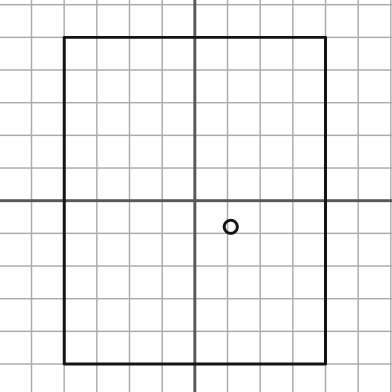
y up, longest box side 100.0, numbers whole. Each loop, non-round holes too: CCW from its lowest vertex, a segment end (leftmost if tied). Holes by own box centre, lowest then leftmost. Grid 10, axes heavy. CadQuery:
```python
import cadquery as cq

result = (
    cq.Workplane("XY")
    .moveTo(-40.0, -50.0)
    .lineTo(40.0, -50.0)
    .lineTo(40.0, 50.0)
    .lineTo(-40.0, 50.0)
    .close()
    .moveTo(11.0, -8.0)
    .circle(2.0)
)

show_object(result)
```